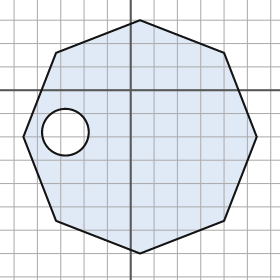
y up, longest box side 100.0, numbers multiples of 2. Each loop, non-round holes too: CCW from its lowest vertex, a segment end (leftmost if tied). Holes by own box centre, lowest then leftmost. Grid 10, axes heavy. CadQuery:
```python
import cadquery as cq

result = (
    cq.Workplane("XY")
    .moveTo(4.0, -70.0)
    .lineTo(40.0, -56.0)
    .lineTo(54.0, -20.0)
    .lineTo(40.0, 16.0)
    .lineTo(4.0, 30.0)
    .lineTo(-32.0, 16.0)
    .lineTo(-46.0, -20.0)
    .lineTo(-32.0, -56.0)
    .close()
    .moveTo(-28.0, -18.0)
    .circle(10.0)
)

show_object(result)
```